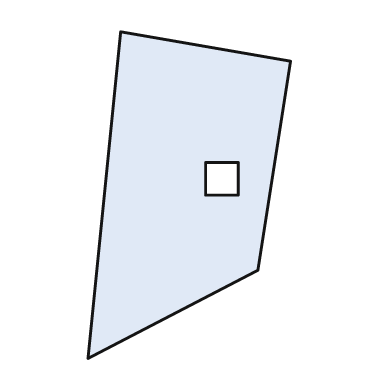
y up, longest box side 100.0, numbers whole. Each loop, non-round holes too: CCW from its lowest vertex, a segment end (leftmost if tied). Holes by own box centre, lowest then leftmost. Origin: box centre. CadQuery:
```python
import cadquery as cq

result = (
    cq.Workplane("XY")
    .moveTo(-31.0, -50.0)
    .lineTo(21.0, -23.0)
    .lineTo(31.0, 41.0)
    .lineTo(-21.0, 50.0)
    .close()
    .moveTo(5.0, 0.0)
    .lineTo(15.0, 0.0)
    .lineTo(15.0, 10.0)
    .lineTo(5.0, 10.0)
    .close()
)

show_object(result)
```